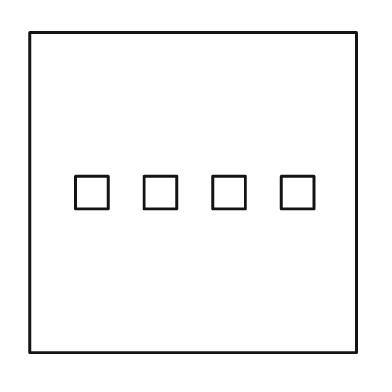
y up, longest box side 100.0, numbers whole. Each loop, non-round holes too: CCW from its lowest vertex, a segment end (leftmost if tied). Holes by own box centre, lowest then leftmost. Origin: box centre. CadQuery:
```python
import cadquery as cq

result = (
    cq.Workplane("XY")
    .moveTo(-50.0, -49.0)
    .lineTo(50.0, -49.0)
    .lineTo(50.0, 49.0)
    .lineTo(-50.0, 49.0)
    .close()
    .moveTo(-36.0, -5.0)
    .lineTo(-26.0, -5.0)
    .lineTo(-26.0, 5.0)
    .lineTo(-36.0, 5.0)
    .close()
    .moveTo(-15.0, -5.0)
    .lineTo(-5.0, -5.0)
    .lineTo(-5.0, 5.0)
    .lineTo(-15.0, 5.0)
    .close()
    .moveTo(6.0, -5.0)
    .lineTo(16.0, -5.0)
    .lineTo(16.0, 5.0)
    .lineTo(6.0, 5.0)
    .close()
    .moveTo(27.0, -5.0)
    .lineTo(37.0, -5.0)
    .lineTo(37.0, 5.0)
    .lineTo(27.0, 5.0)
    .close()
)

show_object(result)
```